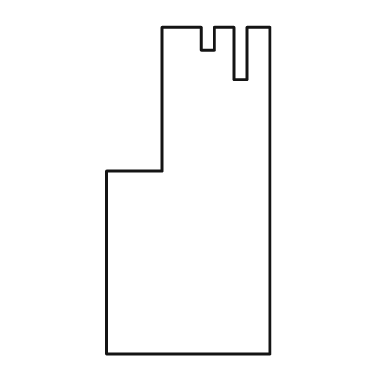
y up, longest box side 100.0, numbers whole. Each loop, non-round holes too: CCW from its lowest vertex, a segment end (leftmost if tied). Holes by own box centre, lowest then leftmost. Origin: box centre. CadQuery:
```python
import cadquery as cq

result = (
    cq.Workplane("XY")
    .moveTo(-25.0, -50.0)
    .lineTo(25.0, -50.0)
    .lineTo(25.0, 50.0)
    .lineTo(18.0, 50.0)
    .lineTo(18.0, 34.0)
    .lineTo(14.0, 34.0)
    .lineTo(14.0, 50.0)
    .lineTo(8.0, 50.0)
    .lineTo(8.0, 43.0)
    .lineTo(4.0, 43.0)
    .lineTo(4.0, 50.0)
    .lineTo(-8.0, 50.0)
    .lineTo(-8.0, 6.0)
    .lineTo(-25.0, 6.0)
    .close()
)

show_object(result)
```